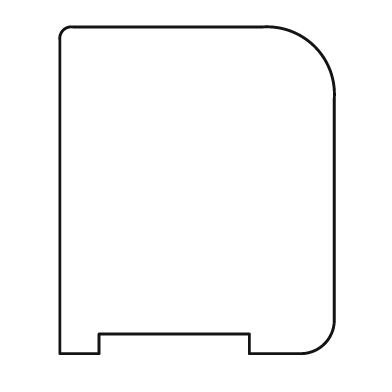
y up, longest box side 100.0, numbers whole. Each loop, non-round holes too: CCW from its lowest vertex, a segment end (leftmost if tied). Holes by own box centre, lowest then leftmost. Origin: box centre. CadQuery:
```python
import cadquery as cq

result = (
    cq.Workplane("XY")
    .moveTo(-42.0, -50.0)
    .lineTo(-30.0, -50.0)
    .lineTo(-30.0, -44.0)
    .lineTo(16.0, -44.0)
    .lineTo(16.0, -50.0)
    .lineTo(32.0, -50.0)
    .threePointArc((39.0, -47.0), (42.0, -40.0))
    .lineTo(42.0, 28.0)
    .threePointArc((36.0, 44.0), (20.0, 50.0))
    .lineTo(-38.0, 50.0)
    .threePointArc((-41.0, 49.0), (-42.0, 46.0))
    .close()
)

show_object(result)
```